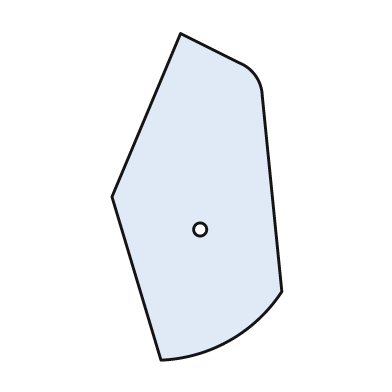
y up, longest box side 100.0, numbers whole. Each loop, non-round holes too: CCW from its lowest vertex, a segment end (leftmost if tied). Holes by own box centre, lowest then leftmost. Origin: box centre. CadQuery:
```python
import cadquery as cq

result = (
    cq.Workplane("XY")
    .moveTo(-11.0, -50.0)
    .threePointArc((10.0, -44.0), (26.0, -29.0))
    .lineTo(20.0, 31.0)
    .threePointArc((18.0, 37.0), (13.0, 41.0))
    .lineTo(-5.0, 50.0)
    .lineTo(-26.0, 0.0)
    .close()
    .moveTo(1.0, -10.0)
    .circle(2.0)
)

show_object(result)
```